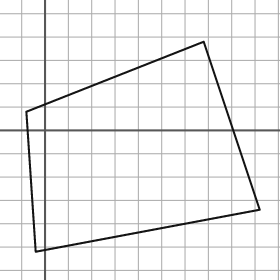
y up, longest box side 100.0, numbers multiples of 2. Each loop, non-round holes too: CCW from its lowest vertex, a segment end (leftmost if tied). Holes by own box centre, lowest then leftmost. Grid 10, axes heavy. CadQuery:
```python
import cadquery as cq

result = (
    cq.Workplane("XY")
    .moveTo(-4.0, -52.0)
    .lineTo(92.0, -34.0)
    .lineTo(68.0, 38.0)
    .lineTo(-8.0, 8.0)
    .close()
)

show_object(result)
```